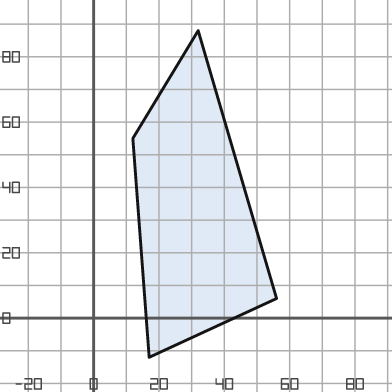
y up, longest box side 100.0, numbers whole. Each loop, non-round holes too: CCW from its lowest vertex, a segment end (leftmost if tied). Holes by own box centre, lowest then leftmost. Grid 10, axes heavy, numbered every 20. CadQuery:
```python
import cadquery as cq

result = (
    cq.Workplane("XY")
    .moveTo(17.0, -12.0)
    .lineTo(56.0, 6.0)
    .lineTo(32.0, 88.0)
    .lineTo(12.0, 55.0)
    .close()
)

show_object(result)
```